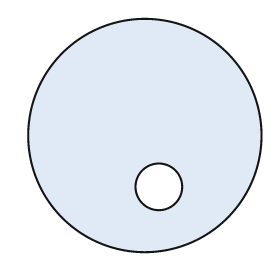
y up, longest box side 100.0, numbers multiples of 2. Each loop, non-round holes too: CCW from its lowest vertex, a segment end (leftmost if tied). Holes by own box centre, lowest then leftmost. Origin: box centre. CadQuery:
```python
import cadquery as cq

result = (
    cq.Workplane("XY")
    .moveTo(0.0, 0.0)
    .circle(50.0)
    .moveTo(6.0, -22.0)
    .circle(10.0)
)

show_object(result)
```